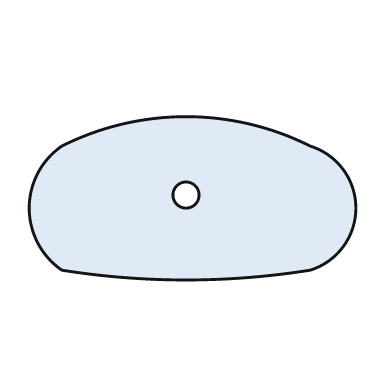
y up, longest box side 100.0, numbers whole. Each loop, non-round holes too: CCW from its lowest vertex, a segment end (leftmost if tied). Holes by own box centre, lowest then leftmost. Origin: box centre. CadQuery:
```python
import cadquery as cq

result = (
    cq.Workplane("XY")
    .moveTo(-40.0, -22.0)
    .threePointArc((-2.0, -25.0), (36.0, -22.0))
    .threePointArc((50.0, -3.0), (36.0, 16.0))
    .threePointArc((-2.0, 25.0), (-40.0, 16.0))
    .threePointArc((-50.0, -3.0), (-40.0, -22.0))
    .close()
    .moveTo(-2.0, 1.0)
    .circle(4.0)
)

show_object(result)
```